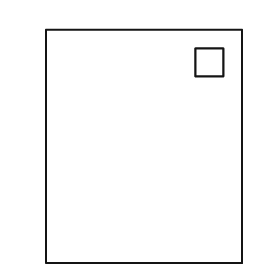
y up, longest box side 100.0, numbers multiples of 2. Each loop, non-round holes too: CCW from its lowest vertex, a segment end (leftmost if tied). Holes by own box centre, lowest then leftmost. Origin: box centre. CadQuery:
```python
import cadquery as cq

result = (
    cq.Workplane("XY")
    .moveTo(-42.0, -50.0)
    .lineTo(42.0, -50.0)
    .lineTo(42.0, 50.0)
    .lineTo(-42.0, 50.0)
    .close()
    .moveTo(22.0, 30.0)
    .lineTo(34.0, 30.0)
    .lineTo(34.0, 42.0)
    .lineTo(22.0, 42.0)
    .close()
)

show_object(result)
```